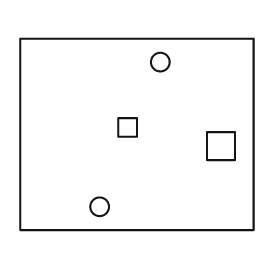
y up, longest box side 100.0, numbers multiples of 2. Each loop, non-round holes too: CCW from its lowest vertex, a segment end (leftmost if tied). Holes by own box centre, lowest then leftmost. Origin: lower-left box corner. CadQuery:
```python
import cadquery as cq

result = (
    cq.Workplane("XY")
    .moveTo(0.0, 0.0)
    .lineTo(100.0, 0.0)
    .lineTo(100.0, 82.0)
    .lineTo(0.0, 82.0)
    .close()
    .moveTo(34.0, 10.0)
    .circle(4.0)
    .moveTo(80.0, 30.0)
    .lineTo(92.0, 30.0)
    .lineTo(92.0, 42.0)
    .lineTo(80.0, 42.0)
    .close()
    .moveTo(42.0, 40.0)
    .lineTo(50.0, 40.0)
    .lineTo(50.0, 48.0)
    .lineTo(42.0, 48.0)
    .close()
    .moveTo(60.0, 72.0)
    .circle(4.0)
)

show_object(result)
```